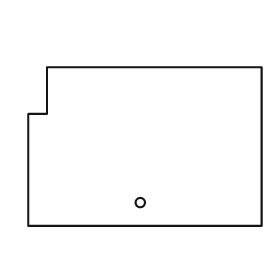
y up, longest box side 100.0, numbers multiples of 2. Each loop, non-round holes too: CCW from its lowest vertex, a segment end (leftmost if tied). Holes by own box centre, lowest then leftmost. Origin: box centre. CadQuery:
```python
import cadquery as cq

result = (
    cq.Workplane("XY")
    .moveTo(-50.0, -34.0)
    .lineTo(50.0, -34.0)
    .lineTo(50.0, 34.0)
    .lineTo(-42.0, 34.0)
    .lineTo(-42.0, 14.0)
    .lineTo(-50.0, 14.0)
    .close()
    .moveTo(-2.0, -24.0)
    .circle(2.0)
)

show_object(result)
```